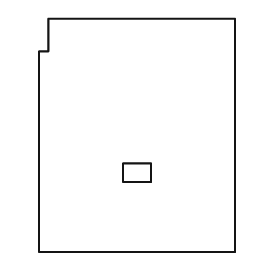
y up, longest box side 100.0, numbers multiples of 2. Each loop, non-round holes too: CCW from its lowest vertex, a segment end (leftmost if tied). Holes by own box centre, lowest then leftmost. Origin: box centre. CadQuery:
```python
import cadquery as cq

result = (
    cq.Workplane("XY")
    .moveTo(-42.0, -50.0)
    .lineTo(42.0, -50.0)
    .lineTo(42.0, 50.0)
    .lineTo(-38.0, 50.0)
    .lineTo(-38.0, 36.0)
    .lineTo(-42.0, 36.0)
    .close()
    .moveTo(-6.0, -20.0)
    .lineTo(6.0, -20.0)
    .lineTo(6.0, -12.0)
    .lineTo(-6.0, -12.0)
    .close()
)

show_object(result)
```